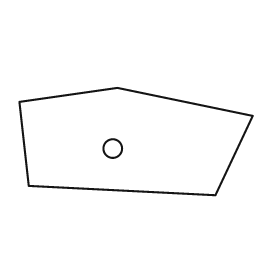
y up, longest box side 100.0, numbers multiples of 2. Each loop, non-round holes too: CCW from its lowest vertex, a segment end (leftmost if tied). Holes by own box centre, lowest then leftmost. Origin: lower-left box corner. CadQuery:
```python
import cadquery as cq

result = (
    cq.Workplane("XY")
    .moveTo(84.0, 0.0)
    .lineTo(100.0, 34.0)
    .lineTo(42.0, 46.0)
    .lineTo(0.0, 40.0)
    .lineTo(4.0, 4.0)
    .close()
    .moveTo(40.0, 20.0)
    .circle(4.0)
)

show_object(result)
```